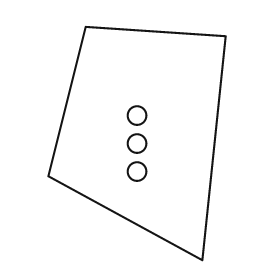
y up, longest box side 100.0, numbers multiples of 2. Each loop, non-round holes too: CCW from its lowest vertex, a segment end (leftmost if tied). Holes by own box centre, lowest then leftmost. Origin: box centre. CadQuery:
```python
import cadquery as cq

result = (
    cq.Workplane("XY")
    .moveTo(28.0, -50.0)
    .lineTo(38.0, 46.0)
    .lineTo(-22.0, 50.0)
    .lineTo(-38.0, -14.0)
    .close()
    .moveTo(0.0, -12.0)
    .circle(4.0)
    .moveTo(0.0, 0.0)
    .circle(4.0)
    .moveTo(0.0, 12.0)
    .circle(4.0)
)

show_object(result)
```